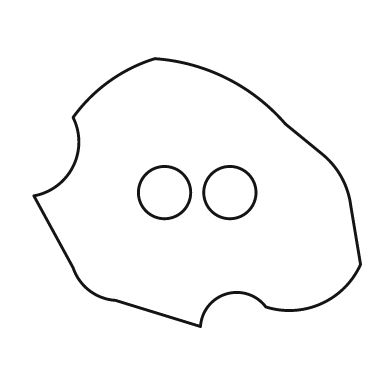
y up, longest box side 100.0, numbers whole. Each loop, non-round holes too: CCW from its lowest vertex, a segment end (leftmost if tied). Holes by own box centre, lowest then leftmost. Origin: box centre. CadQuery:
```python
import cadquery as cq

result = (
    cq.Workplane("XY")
    .moveTo(1.0, -41.0)
    .threePointArc((9.0, -31.0), (21.0, -35.0))
    .threePointArc((38.0, -34.0), (50.0, -22.0))
    .lineTo(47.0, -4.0)
    .threePointArc((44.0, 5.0), (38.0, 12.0))
    .lineTo(27.0, 21.0)
    .threePointArc((9.0, 35.0), (-13.0, 41.0))
    .threePointArc((-27.0, 34.0), (-38.0, 23.0))
    .threePointArc((-38.0, 8.0), (-50.0, -1.0))
    .lineTo(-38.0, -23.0)
    .threePointArc((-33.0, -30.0), (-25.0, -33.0))
    .close()
    .moveTo(-10.0, 0.0)
    .circle(8.0)
    .moveTo(10.0, 0.0)
    .circle(8.0)
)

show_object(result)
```